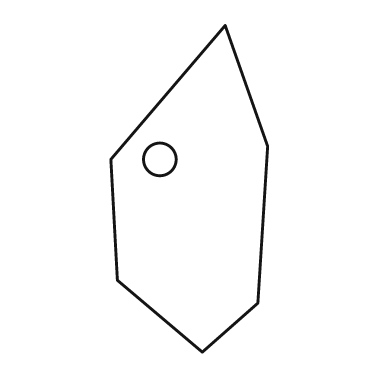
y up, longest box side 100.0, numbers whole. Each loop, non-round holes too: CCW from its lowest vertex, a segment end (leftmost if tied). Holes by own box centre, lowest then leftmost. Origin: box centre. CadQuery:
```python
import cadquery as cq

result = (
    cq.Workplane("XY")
    .moveTo(4.0, -50.0)
    .lineTo(21.0, -35.0)
    .lineTo(24.0, 13.0)
    .lineTo(11.0, 50.0)
    .lineTo(-24.0, 9.0)
    .lineTo(-22.0, -28.0)
    .close()
    .moveTo(-9.0, 9.0)
    .circle(5.0)
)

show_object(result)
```